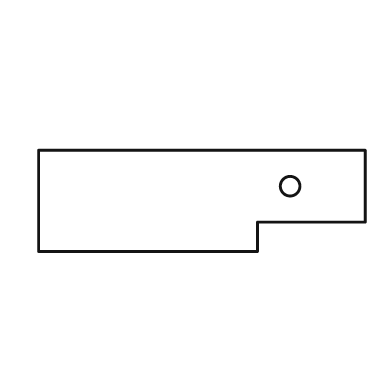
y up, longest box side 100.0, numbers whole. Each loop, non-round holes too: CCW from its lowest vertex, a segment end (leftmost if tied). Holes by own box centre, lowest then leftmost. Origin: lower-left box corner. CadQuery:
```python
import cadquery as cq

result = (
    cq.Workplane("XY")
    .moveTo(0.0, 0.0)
    .lineTo(67.0, 0.0)
    .lineTo(67.0, 9.0)
    .lineTo(100.0, 9.0)
    .lineTo(100.0, 31.0)
    .lineTo(0.0, 31.0)
    .close()
    .moveTo(77.0, 20.0)
    .circle(3.0)
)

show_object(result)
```